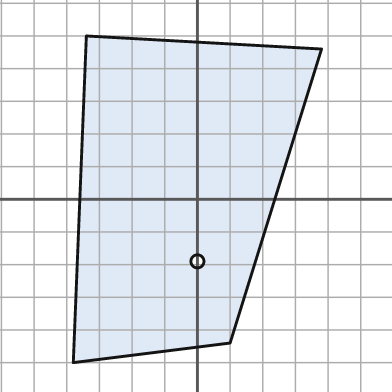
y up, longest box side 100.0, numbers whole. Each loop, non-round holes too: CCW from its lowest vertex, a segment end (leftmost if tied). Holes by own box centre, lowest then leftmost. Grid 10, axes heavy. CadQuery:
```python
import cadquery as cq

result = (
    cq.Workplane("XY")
    .moveTo(-38.0, -50.0)
    .lineTo(10.0, -44.0)
    .lineTo(38.0, 46.0)
    .lineTo(-34.0, 50.0)
    .close()
    .moveTo(0.0, -19.0)
    .circle(2.0)
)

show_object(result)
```